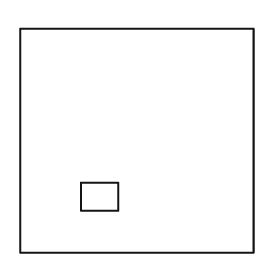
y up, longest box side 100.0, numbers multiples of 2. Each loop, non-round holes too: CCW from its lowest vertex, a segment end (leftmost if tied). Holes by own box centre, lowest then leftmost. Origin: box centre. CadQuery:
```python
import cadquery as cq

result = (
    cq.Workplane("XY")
    .moveTo(-50.0, -48.0)
    .lineTo(50.0, -48.0)
    .lineTo(50.0, 48.0)
    .lineTo(-50.0, 48.0)
    .close()
    .moveTo(-24.0, -30.0)
    .lineTo(-8.0, -30.0)
    .lineTo(-8.0, -18.0)
    .lineTo(-24.0, -18.0)
    .close()
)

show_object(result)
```